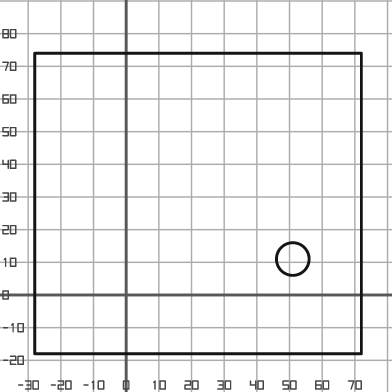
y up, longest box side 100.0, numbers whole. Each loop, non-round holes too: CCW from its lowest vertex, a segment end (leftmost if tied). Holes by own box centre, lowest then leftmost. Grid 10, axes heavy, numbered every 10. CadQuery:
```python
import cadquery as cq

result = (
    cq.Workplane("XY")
    .moveTo(-28.0, -18.0)
    .lineTo(72.0, -18.0)
    .lineTo(72.0, 74.0)
    .lineTo(-28.0, 74.0)
    .close()
    .moveTo(51.0, 11.0)
    .circle(5.0)
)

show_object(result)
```